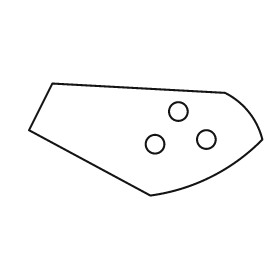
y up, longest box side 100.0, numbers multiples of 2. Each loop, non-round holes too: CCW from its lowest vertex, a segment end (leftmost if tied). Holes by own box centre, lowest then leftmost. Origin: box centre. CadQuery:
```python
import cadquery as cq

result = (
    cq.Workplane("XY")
    .moveTo(2.0, -24.0)
    .threePointArc((28.0, -16.0), (50.0, 0.0))
    .threePointArc((44.0, 12.0), (34.0, 20.0))
    .lineTo(-40.0, 24.0)
    .lineTo(-50.0, 4.0)
    .close()
    .moveTo(4.0, -2.0)
    .circle(4.0)
    .moveTo(26.0, 0.0)
    .circle(4.0)
    .moveTo(14.0, 12.0)
    .circle(4.0)
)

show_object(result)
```